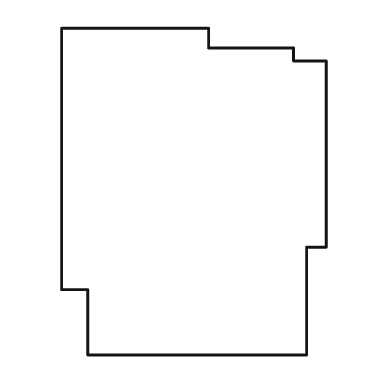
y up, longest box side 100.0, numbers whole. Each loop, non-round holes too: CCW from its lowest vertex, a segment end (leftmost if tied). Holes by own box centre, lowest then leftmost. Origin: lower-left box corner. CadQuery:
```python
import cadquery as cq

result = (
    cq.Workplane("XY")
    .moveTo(8.0, 0.0)
    .lineTo(75.0, 0.0)
    .lineTo(75.0, 33.0)
    .lineTo(81.0, 33.0)
    .lineTo(81.0, 90.0)
    .lineTo(71.0, 90.0)
    .lineTo(71.0, 94.0)
    .lineTo(45.0, 94.0)
    .lineTo(45.0, 100.0)
    .lineTo(0.0, 100.0)
    .lineTo(0.0, 20.0)
    .lineTo(8.0, 20.0)
    .close()
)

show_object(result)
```